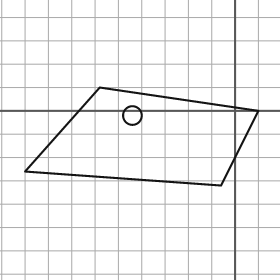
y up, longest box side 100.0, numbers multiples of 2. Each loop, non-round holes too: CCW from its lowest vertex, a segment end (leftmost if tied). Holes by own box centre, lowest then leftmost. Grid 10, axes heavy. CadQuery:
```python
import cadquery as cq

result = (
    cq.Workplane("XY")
    .moveTo(-6.0, -32.0)
    .lineTo(10.0, 0.0)
    .lineTo(-58.0, 10.0)
    .lineTo(-90.0, -26.0)
    .close()
    .moveTo(-44.0, -2.0)
    .circle(4.0)
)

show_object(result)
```